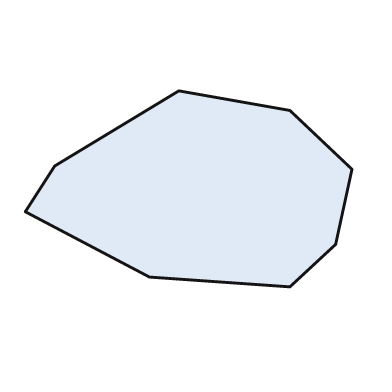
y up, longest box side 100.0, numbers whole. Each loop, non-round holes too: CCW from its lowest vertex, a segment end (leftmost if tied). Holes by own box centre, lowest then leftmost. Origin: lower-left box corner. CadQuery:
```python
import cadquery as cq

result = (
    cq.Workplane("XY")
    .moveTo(81.0, 0.0)
    .lineTo(95.0, 13.0)
    .lineTo(100.0, 36.0)
    .lineTo(81.0, 54.0)
    .lineTo(47.0, 60.0)
    .lineTo(9.0, 37.0)
    .lineTo(0.0, 23.0)
    .lineTo(38.0, 3.0)
    .close()
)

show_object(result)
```